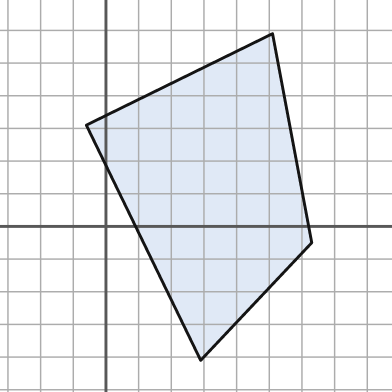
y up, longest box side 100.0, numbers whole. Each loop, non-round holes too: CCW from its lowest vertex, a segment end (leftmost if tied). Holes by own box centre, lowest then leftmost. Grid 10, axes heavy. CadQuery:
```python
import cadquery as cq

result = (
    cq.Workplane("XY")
    .moveTo(29.0, -41.0)
    .lineTo(63.0, -5.0)
    .lineTo(51.0, 59.0)
    .lineTo(-6.0, 31.0)
    .close()
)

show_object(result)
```